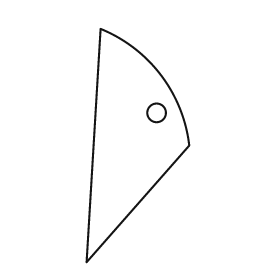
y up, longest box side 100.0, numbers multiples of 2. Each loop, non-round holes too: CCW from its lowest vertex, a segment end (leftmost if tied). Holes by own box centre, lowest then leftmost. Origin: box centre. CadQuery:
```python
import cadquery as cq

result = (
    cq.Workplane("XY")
    .moveTo(-22.0, -50.0)
    .lineTo(22.0, 0.0)
    .threePointArc((10.0, 30.0), (-16.0, 50.0))
    .close()
    .moveTo(8.0, 14.0)
    .circle(4.0)
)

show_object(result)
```